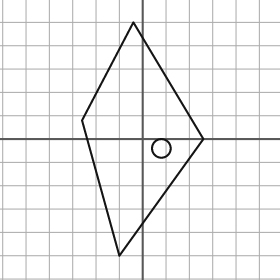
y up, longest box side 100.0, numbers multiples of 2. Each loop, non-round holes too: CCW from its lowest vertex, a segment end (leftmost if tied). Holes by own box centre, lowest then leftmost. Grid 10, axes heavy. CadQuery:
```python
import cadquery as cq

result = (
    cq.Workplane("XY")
    .moveTo(-10.0, -50.0)
    .lineTo(26.0, 0.0)
    .lineTo(-4.0, 50.0)
    .lineTo(-26.0, 8.0)
    .close()
    .moveTo(8.0, -4.0)
    .circle(4.0)
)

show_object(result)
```